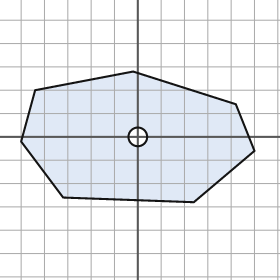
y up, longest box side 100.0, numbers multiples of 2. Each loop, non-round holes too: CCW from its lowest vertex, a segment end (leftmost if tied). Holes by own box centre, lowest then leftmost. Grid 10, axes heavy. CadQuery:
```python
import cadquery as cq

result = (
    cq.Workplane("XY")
    .moveTo(24.0, -28.0)
    .lineTo(50.0, -6.0)
    .lineTo(42.0, 14.0)
    .lineTo(-2.0, 28.0)
    .lineTo(-44.0, 20.0)
    .lineTo(-50.0, -2.0)
    .lineTo(-32.0, -26.0)
    .close()
    .moveTo(0.0, 0.0)
    .circle(4.0)
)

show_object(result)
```